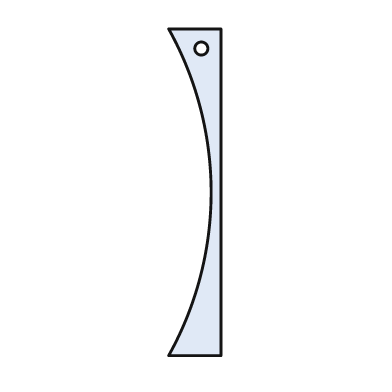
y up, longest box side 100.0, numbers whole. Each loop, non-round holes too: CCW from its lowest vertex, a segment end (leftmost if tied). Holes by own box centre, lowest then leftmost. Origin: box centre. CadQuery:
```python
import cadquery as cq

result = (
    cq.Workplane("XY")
    .moveTo(-8.0, -50.0)
    .lineTo(8.0, -50.0)
    .lineTo(8.0, 50.0)
    .lineTo(-8.0, 50.0)
    .threePointArc((5.0, 0.0), (-8.0, -50.0))
    .close()
    .moveTo(2.0, 44.0)
    .circle(2.0)
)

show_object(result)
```